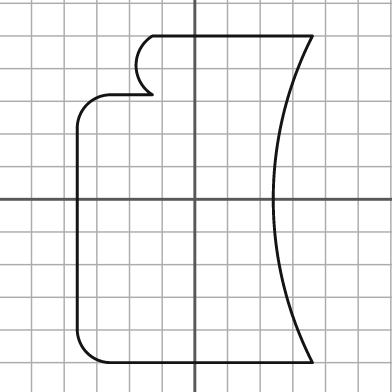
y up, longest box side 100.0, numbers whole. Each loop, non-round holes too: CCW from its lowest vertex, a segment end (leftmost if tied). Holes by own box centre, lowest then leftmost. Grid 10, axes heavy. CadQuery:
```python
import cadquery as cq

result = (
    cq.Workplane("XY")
    .moveTo(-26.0, -50.0)
    .lineTo(36.0, -50.0)
    .threePointArc((24.0, 0.0), (36.0, 50.0))
    .lineTo(-13.0, 50.0)
    .threePointArc((-18.0, 41.0), (-13.0, 32.0))
    .lineTo(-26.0, 32.0)
    .threePointArc((-33.0, 29.0), (-36.0, 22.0))
    .lineTo(-36.0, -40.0)
    .threePointArc((-33.0, -47.0), (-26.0, -50.0))
    .close()
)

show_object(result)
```